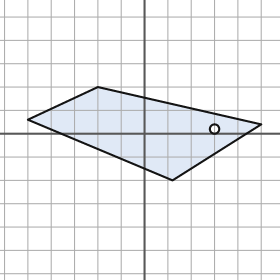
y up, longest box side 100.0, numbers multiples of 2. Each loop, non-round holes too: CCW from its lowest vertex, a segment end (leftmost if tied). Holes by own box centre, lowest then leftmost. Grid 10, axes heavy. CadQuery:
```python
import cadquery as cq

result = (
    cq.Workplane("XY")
    .moveTo(12.0, -20.0)
    .lineTo(50.0, 4.0)
    .lineTo(-20.0, 20.0)
    .lineTo(-50.0, 6.0)
    .close()
    .moveTo(30.0, 2.0)
    .circle(2.0)
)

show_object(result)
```